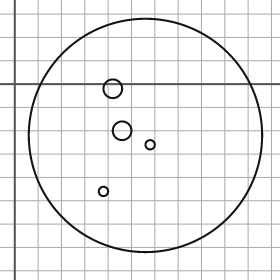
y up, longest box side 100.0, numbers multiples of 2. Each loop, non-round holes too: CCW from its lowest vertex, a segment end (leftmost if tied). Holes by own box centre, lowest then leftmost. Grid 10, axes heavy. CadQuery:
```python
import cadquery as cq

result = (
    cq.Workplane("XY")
    .moveTo(56.0, -22.0)
    .circle(50.0)
    .moveTo(38.0, -46.0)
    .circle(2.0)
    .moveTo(58.0, -26.0)
    .circle(2.0)
    .moveTo(46.0, -20.0)
    .circle(4.0)
    .moveTo(42.0, -2.0)
    .circle(4.0)
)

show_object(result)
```